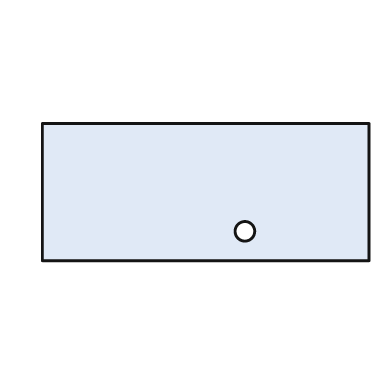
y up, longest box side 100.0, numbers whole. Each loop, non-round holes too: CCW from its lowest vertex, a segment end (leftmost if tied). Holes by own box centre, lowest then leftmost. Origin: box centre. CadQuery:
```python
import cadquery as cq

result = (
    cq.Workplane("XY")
    .moveTo(-50.0, -21.0)
    .lineTo(50.0, -21.0)
    .lineTo(50.0, 21.0)
    .lineTo(-50.0, 21.0)
    .close()
    .moveTo(12.0, -12.0)
    .circle(3.0)
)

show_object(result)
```